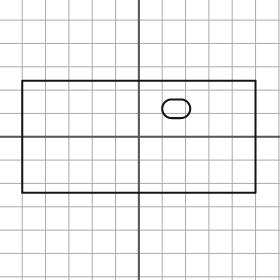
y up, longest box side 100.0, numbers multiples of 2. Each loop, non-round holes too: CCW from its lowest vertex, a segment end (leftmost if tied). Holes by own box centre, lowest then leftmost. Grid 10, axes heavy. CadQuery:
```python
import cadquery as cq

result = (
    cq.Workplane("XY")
    .moveTo(-50.0, -24.0)
    .lineTo(50.0, -24.0)
    .lineTo(50.0, 24.0)
    .lineTo(-50.0, 24.0)
    .close()
    .moveTo(14.0, 8.0)
    .lineTo(18.0, 8.0)
    .threePointArc((22.0, 12.0), (18.0, 16.0))
    .lineTo(14.0, 16.0)
    .threePointArc((10.0, 12.0), (14.0, 8.0))
    .close()
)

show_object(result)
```